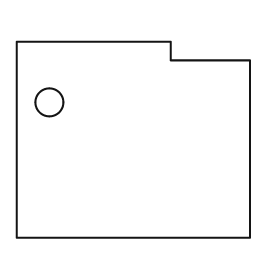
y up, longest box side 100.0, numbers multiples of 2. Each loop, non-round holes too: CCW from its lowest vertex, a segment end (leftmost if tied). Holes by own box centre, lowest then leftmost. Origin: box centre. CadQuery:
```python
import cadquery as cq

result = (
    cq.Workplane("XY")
    .moveTo(-50.0, -42.0)
    .lineTo(50.0, -42.0)
    .lineTo(50.0, 34.0)
    .lineTo(16.0, 34.0)
    .lineTo(16.0, 42.0)
    .lineTo(-50.0, 42.0)
    .close()
    .moveTo(-36.0, 16.0)
    .circle(6.0)
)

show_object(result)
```